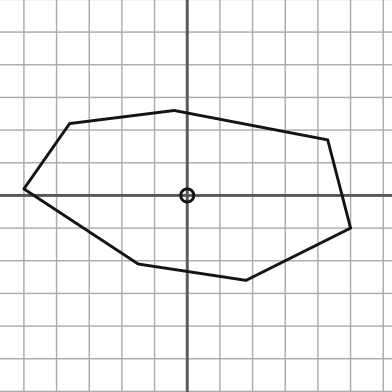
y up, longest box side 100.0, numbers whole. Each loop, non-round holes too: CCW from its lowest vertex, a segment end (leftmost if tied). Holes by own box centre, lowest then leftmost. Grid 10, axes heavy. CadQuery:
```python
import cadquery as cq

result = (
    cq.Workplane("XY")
    .moveTo(18.0, -26.0)
    .lineTo(50.0, -10.0)
    .lineTo(43.0, 17.0)
    .lineTo(-4.0, 26.0)
    .lineTo(-36.0, 22.0)
    .lineTo(-50.0, 2.0)
    .lineTo(-15.0, -21.0)
    .close()
    .moveTo(0.0, 0.0)
    .circle(2.0)
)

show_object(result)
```